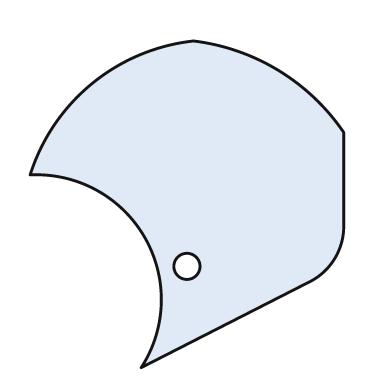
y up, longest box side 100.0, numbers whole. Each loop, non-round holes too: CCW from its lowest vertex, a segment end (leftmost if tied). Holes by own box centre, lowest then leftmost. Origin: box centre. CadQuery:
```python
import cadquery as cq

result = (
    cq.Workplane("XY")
    .moveTo(-14.0, -50.0)
    .lineTo(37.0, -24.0)
    .threePointArc((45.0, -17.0), (48.0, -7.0))
    .lineTo(48.0, 22.0)
    .threePointArc((28.0, 41.0), (2.0, 50.0))
    .threePointArc((-29.0, 37.0), (-48.0, 9.0))
    .threePointArc((-13.0, -10.0), (-14.0, -50.0))
    .close()
    .moveTo(0.0, -19.0)
    .circle(4.0)
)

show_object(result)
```